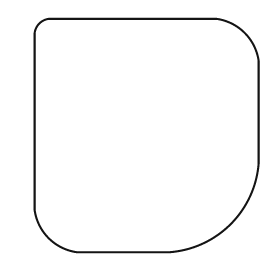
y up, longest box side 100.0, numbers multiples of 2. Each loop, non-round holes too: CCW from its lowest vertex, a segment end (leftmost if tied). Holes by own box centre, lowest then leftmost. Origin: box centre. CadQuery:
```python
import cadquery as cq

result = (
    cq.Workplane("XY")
    .moveTo(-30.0, -50.0)
    .lineTo(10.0, -50.0)
    .threePointArc((36.0, -38.0), (48.0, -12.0))
    .lineTo(48.0, 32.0)
    .threePointArc((42.0, 44.0), (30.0, 50.0))
    .lineTo(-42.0, 50.0)
    .threePointArc((-46.0, 48.0), (-48.0, 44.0))
    .lineTo(-48.0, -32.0)
    .threePointArc((-42.0, -44.0), (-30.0, -50.0))
    .close()
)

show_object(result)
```